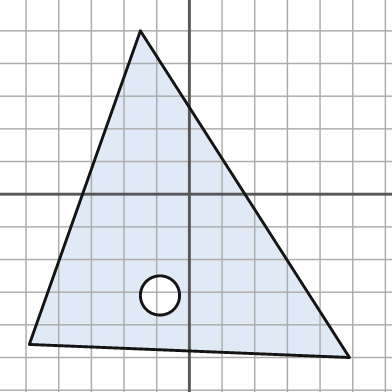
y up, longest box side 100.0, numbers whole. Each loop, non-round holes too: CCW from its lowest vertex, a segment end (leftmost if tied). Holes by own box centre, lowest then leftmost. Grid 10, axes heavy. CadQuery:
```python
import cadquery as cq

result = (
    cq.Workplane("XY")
    .moveTo(49.0, -50.0)
    .lineTo(-15.0, 50.0)
    .lineTo(-49.0, -46.0)
    .close()
    .moveTo(-9.0, -31.0)
    .circle(6.0)
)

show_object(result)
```